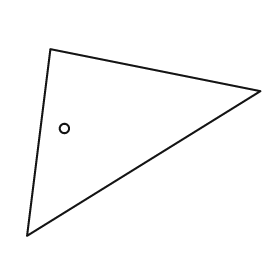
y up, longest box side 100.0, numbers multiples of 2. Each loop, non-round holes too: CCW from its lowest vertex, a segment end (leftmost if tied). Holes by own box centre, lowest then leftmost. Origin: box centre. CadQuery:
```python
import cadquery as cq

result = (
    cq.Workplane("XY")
    .moveTo(-50.0, -40.0)
    .lineTo(50.0, 22.0)
    .lineTo(-40.0, 40.0)
    .close()
    .moveTo(-34.0, 6.0)
    .circle(2.0)
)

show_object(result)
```